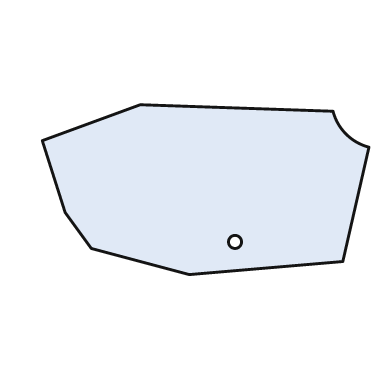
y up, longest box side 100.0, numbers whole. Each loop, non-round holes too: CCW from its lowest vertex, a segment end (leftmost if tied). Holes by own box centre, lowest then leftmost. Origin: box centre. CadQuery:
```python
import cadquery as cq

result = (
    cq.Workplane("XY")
    .moveTo(-5.0, -26.0)
    .lineTo(42.0, -22.0)
    .lineTo(50.0, 13.0)
    .threePointArc((43.0, 17.0), (39.0, 24.0))
    .lineTo(-20.0, 26.0)
    .lineTo(-50.0, 15.0)
    .lineTo(-43.0, -7.0)
    .lineTo(-35.0, -18.0)
    .close()
    .moveTo(9.0, -16.0)
    .circle(2.0)
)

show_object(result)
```